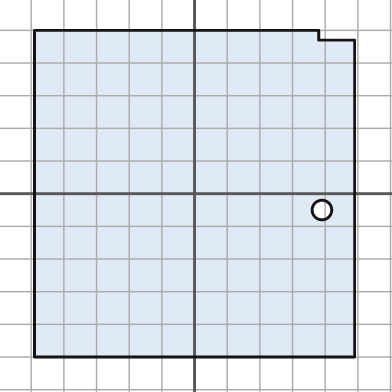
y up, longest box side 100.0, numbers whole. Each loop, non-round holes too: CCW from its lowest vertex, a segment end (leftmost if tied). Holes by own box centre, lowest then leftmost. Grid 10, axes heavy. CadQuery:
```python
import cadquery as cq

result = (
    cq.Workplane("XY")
    .moveTo(-49.0, -50.0)
    .lineTo(49.0, -50.0)
    .lineTo(49.0, 47.0)
    .lineTo(38.0, 47.0)
    .lineTo(38.0, 50.0)
    .lineTo(-49.0, 50.0)
    .close()
    .moveTo(39.0, -5.0)
    .circle(3.0)
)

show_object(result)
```